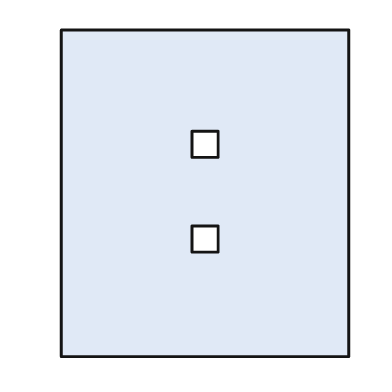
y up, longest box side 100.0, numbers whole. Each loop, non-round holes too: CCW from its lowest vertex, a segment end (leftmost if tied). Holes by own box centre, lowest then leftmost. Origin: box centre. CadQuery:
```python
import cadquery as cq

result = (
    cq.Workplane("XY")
    .moveTo(-44.0, -50.0)
    .lineTo(44.0, -50.0)
    .lineTo(44.0, 50.0)
    .lineTo(-44.0, 50.0)
    .close()
    .moveTo(-4.0, -18.0)
    .lineTo(4.0, -18.0)
    .lineTo(4.0, -10.0)
    .lineTo(-4.0, -10.0)
    .close()
    .moveTo(-4.0, 11.0)
    .lineTo(4.0, 11.0)
    .lineTo(4.0, 19.0)
    .lineTo(-4.0, 19.0)
    .close()
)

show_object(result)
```